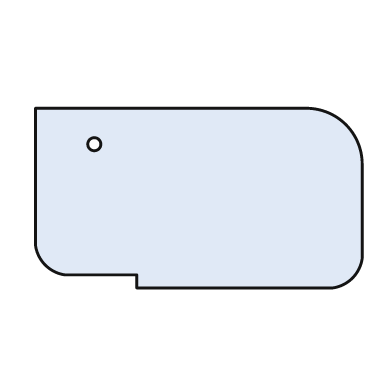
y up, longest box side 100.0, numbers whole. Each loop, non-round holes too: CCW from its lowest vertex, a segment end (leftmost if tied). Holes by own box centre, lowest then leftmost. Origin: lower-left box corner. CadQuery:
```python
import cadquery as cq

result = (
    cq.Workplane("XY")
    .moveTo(31.0, 0.0)
    .lineTo(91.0, 0.0)
    .threePointArc((97.0, 3.0), (100.0, 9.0))
    .lineTo(100.0, 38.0)
    .threePointArc((95.0, 50.0), (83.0, 55.0))
    .lineTo(0.0, 55.0)
    .lineTo(0.0, 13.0)
    .threePointArc((3.0, 7.0), (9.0, 4.0))
    .lineTo(31.0, 4.0)
    .close()
    .moveTo(18.0, 44.0)
    .circle(2.0)
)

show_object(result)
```